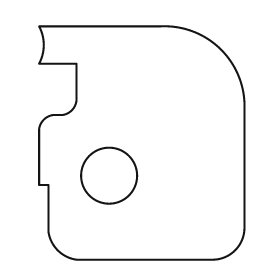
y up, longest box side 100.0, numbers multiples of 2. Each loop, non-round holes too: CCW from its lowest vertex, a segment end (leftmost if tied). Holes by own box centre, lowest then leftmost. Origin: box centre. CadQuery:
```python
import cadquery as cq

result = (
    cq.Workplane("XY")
    .moveTo(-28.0, -50.0)
    .lineTo(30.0, -50.0)
    .threePointArc((40.0, -46.0), (44.0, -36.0))
    .lineTo(44.0, 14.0)
    .threePointArc((34.0, 40.0), (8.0, 50.0))
    .lineTo(-44.0, 50.0)
    .threePointArc((-42.0, 42.0), (-44.0, 34.0))
    .lineTo(-28.0, 34.0)
    .lineTo(-28.0, 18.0)
    .threePointArc((-30.0, 14.0), (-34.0, 12.0))
    .lineTo(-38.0, 12.0)
    .threePointArc((-42.0, 10.0), (-44.0, 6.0))
    .lineTo(-44.0, -18.0)
    .lineTo(-40.0, -18.0)
    .lineTo(-40.0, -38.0)
    .threePointArc((-36.0, -46.0), (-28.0, -50.0))
    .close()
    .moveTo(-14.0, -14.0)
    .circle(12.0)
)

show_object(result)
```